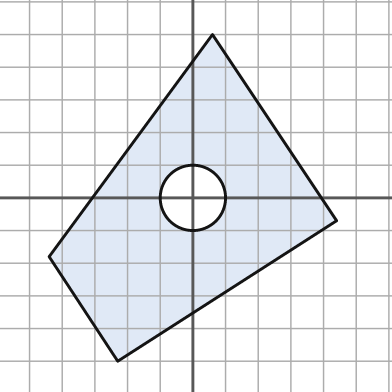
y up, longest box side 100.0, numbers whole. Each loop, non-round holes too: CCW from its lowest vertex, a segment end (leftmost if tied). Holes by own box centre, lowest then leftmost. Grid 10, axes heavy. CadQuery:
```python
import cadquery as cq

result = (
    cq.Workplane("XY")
    .moveTo(-23.0, -50.0)
    .lineTo(44.0, -7.0)
    .lineTo(6.0, 50.0)
    .lineTo(-44.0, -18.0)
    .close()
    .moveTo(0.0, 0.0)
    .circle(10.0)
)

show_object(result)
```